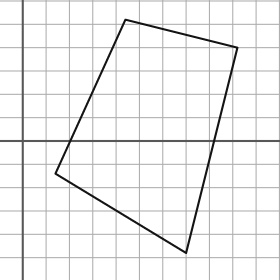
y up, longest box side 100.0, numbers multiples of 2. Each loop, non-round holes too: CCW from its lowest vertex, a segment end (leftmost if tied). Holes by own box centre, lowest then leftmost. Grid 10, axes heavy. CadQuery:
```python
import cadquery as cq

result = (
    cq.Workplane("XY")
    .moveTo(70.0, -48.0)
    .lineTo(92.0, 40.0)
    .lineTo(44.0, 52.0)
    .lineTo(14.0, -14.0)
    .close()
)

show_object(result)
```